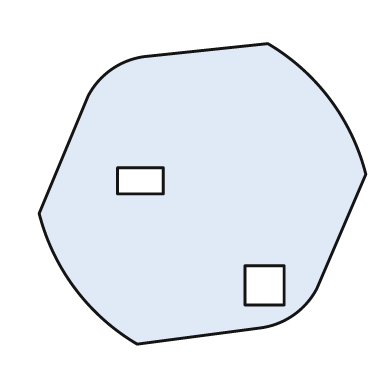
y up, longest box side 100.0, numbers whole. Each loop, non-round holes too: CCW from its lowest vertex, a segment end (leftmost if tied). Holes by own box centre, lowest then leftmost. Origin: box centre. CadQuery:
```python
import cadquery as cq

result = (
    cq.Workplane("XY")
    .moveTo(-20.0, -46.0)
    .lineTo(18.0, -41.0)
    .threePointArc((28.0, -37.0), (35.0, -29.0))
    .lineTo(50.0, 6.0)
    .threePointArc((39.0, 29.0), (20.0, 46.0))
    .lineTo(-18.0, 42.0)
    .threePointArc((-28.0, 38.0), (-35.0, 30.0))
    .lineTo(-50.0, -6.0)
    .threePointArc((-39.0, -29.0), (-20.0, -46.0))
    .close()
    .moveTo(13.0, -34.0)
    .lineTo(25.0, -34.0)
    .lineTo(25.0, -22.0)
    .lineTo(13.0, -22.0)
    .close()
    .moveTo(-26.0, 0.0)
    .lineTo(-12.0, 0.0)
    .lineTo(-12.0, 8.0)
    .lineTo(-26.0, 8.0)
    .close()
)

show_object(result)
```